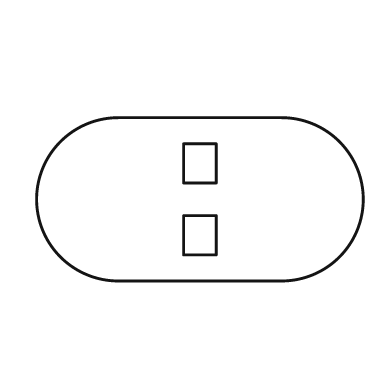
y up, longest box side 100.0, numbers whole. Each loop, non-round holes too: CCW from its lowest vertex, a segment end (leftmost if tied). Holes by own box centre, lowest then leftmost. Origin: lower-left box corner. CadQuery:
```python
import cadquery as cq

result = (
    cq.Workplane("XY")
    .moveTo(25.0, 0.0)
    .lineTo(75.0, 0.0)
    .threePointArc((100.0, 25.0), (75.0, 50.0))
    .lineTo(25.0, 50.0)
    .threePointArc((0.0, 25.0), (25.0, 0.0))
    .close()
    .moveTo(45.0, 8.0)
    .lineTo(55.0, 8.0)
    .lineTo(55.0, 20.0)
    .lineTo(45.0, 20.0)
    .close()
    .moveTo(45.0, 30.0)
    .lineTo(55.0, 30.0)
    .lineTo(55.0, 42.0)
    .lineTo(45.0, 42.0)
    .close()
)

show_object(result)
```